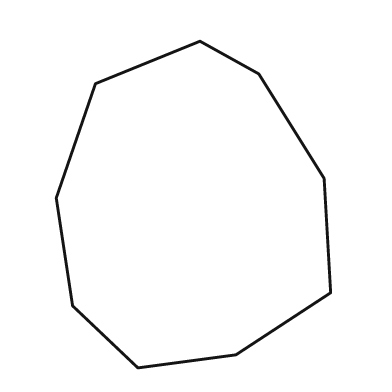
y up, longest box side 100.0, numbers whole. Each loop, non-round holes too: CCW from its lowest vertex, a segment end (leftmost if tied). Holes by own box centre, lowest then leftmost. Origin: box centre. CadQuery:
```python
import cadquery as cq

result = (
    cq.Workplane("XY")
    .moveTo(-17.0, -50.0)
    .lineTo(13.0, -46.0)
    .lineTo(42.0, -27.0)
    .lineTo(40.0, 8.0)
    .lineTo(20.0, 40.0)
    .lineTo(2.0, 50.0)
    .lineTo(-30.0, 37.0)
    .lineTo(-42.0, 2.0)
    .lineTo(-37.0, -31.0)
    .close()
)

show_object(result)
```